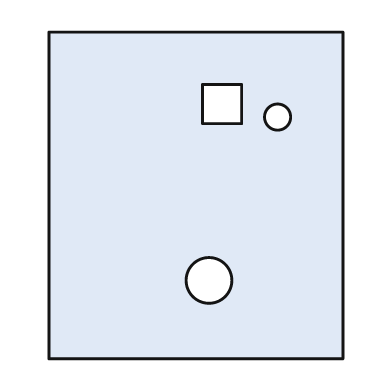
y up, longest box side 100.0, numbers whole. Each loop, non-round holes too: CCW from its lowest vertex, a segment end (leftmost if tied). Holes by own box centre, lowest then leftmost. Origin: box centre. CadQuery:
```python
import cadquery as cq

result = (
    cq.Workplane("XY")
    .moveTo(-45.0, -50.0)
    .lineTo(45.0, -50.0)
    .lineTo(45.0, 50.0)
    .lineTo(-45.0, 50.0)
    .close()
    .moveTo(4.0, -26.0)
    .circle(7.0)
    .moveTo(25.0, 24.0)
    .circle(4.0)
    .moveTo(2.0, 22.0)
    .lineTo(14.0, 22.0)
    .lineTo(14.0, 34.0)
    .lineTo(2.0, 34.0)
    .close()
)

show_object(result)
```